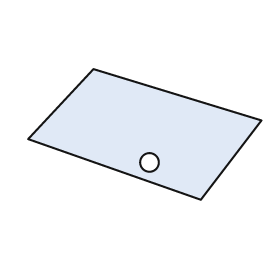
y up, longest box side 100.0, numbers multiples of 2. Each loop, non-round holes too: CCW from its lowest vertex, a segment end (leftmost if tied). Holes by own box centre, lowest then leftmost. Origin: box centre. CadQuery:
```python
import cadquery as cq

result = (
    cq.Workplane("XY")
    .moveTo(24.0, -28.0)
    .lineTo(50.0, 6.0)
    .lineTo(-22.0, 28.0)
    .lineTo(-50.0, -2.0)
    .close()
    .moveTo(2.0, -12.0)
    .circle(4.0)
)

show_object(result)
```